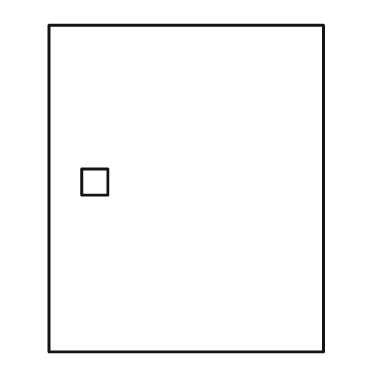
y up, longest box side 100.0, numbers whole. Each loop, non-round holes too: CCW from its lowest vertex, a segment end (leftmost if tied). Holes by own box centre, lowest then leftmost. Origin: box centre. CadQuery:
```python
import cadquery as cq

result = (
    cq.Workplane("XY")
    .moveTo(-42.0, -50.0)
    .lineTo(42.0, -50.0)
    .lineTo(42.0, 50.0)
    .lineTo(-42.0, 50.0)
    .close()
    .moveTo(-32.0, -2.0)
    .lineTo(-24.0, -2.0)
    .lineTo(-24.0, 6.0)
    .lineTo(-32.0, 6.0)
    .close()
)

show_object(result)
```